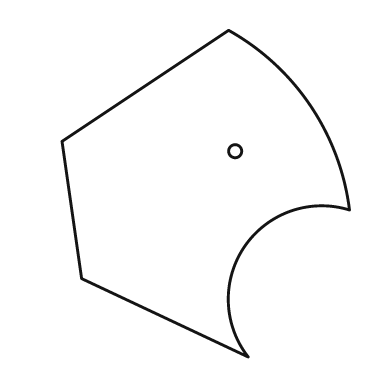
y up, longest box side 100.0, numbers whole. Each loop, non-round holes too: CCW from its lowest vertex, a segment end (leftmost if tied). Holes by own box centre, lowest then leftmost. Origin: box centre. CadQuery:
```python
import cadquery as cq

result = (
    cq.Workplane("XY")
    .moveTo(13.0, -50.0)
    .threePointArc((12.0, -16.0), (44.0, -5.0))
    .threePointArc((32.0, 27.0), (7.0, 50.0))
    .lineTo(-44.0, 16.0)
    .lineTo(-38.0, -26.0)
    .close()
    .moveTo(9.0, 13.0)
    .circle(2.0)
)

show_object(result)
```